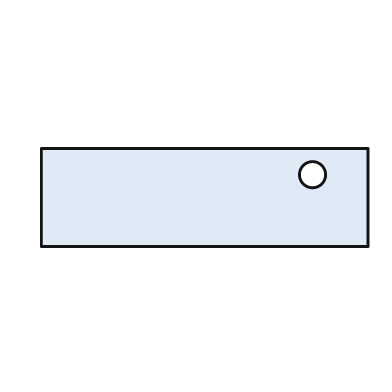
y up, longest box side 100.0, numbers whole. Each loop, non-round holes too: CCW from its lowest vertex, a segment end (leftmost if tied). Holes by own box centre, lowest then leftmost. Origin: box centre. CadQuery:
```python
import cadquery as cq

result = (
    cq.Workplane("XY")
    .moveTo(-50.0, -15.0)
    .lineTo(50.0, -15.0)
    .lineTo(50.0, 15.0)
    .lineTo(-50.0, 15.0)
    .close()
    .moveTo(33.0, 7.0)
    .circle(4.0)
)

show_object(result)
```